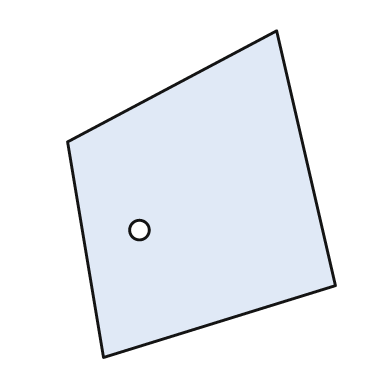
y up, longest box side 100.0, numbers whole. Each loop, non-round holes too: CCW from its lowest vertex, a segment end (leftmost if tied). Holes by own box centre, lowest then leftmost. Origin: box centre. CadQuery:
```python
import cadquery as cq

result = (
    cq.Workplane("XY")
    .moveTo(-30.0, -50.0)
    .lineTo(41.0, -28.0)
    .lineTo(23.0, 50.0)
    .lineTo(-41.0, 16.0)
    .close()
    .moveTo(-19.0, -11.0)
    .circle(3.0)
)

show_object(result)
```